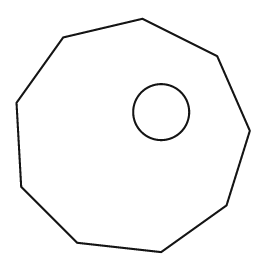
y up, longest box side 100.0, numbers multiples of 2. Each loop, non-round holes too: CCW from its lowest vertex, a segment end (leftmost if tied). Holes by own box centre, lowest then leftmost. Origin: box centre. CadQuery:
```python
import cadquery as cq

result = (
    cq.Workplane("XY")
    .moveTo(12.0, -50.0)
    .lineTo(40.0, -30.0)
    .lineTo(50.0, 2.0)
    .lineTo(36.0, 34.0)
    .lineTo(4.0, 50.0)
    .lineTo(-30.0, 42.0)
    .lineTo(-50.0, 14.0)
    .lineTo(-48.0, -22.0)
    .lineTo(-24.0, -46.0)
    .close()
    .moveTo(12.0, 10.0)
    .circle(12.0)
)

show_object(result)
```